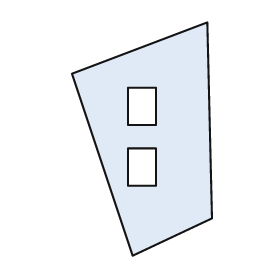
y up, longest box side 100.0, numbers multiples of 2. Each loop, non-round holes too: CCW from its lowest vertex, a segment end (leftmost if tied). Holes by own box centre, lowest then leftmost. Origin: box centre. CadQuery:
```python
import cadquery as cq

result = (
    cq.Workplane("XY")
    .moveTo(-4.0, -50.0)
    .lineTo(30.0, -34.0)
    .lineTo(28.0, 50.0)
    .lineTo(-30.0, 28.0)
    .close()
    .moveTo(-6.0, -20.0)
    .lineTo(6.0, -20.0)
    .lineTo(6.0, -4.0)
    .lineTo(-6.0, -4.0)
    .close()
    .moveTo(-6.0, 6.0)
    .lineTo(6.0, 6.0)
    .lineTo(6.0, 22.0)
    .lineTo(-6.0, 22.0)
    .close()
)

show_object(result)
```